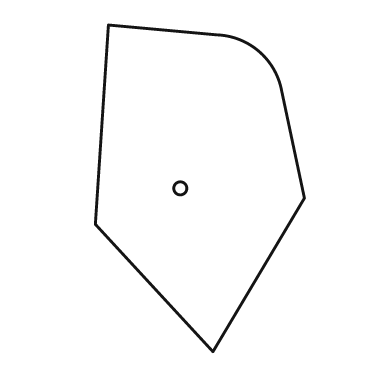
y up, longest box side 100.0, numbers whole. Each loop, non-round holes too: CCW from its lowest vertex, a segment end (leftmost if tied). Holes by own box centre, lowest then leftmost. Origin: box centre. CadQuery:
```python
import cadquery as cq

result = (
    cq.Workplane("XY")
    .moveTo(4.0, -50.0)
    .lineTo(32.0, -3.0)
    .lineTo(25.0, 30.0)
    .threePointArc((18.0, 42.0), (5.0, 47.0))
    .lineTo(-28.0, 50.0)
    .lineTo(-32.0, -11.0)
    .close()
    .moveTo(-6.0, 0.0)
    .circle(2.0)
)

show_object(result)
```